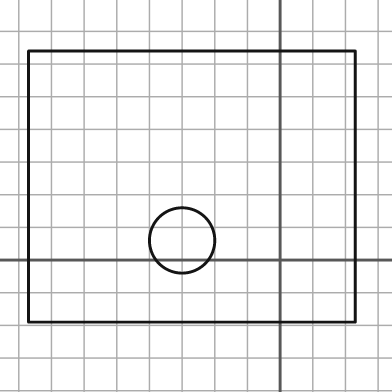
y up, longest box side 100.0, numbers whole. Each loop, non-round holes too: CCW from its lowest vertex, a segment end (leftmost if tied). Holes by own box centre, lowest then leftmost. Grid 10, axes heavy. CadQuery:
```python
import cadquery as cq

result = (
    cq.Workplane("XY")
    .moveTo(-77.0, -19.0)
    .lineTo(23.0, -19.0)
    .lineTo(23.0, 64.0)
    .lineTo(-77.0, 64.0)
    .close()
    .moveTo(-30.0, 6.0)
    .circle(10.0)
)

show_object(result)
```